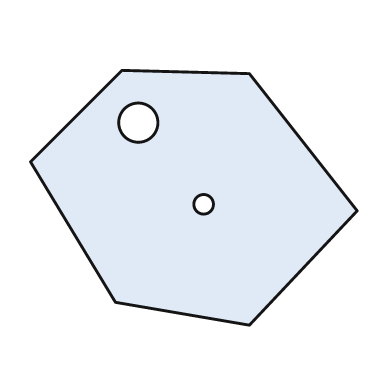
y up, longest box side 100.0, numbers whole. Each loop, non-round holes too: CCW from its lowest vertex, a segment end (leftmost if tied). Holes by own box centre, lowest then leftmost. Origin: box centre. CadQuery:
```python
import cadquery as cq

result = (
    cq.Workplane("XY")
    .moveTo(17.0, -39.0)
    .lineTo(50.0, -4.0)
    .lineTo(17.0, 38.0)
    .lineTo(-22.0, 39.0)
    .lineTo(-50.0, 11.0)
    .lineTo(-24.0, -32.0)
    .close()
    .moveTo(3.0, -2.0)
    .circle(3.0)
    .moveTo(-17.0, 23.0)
    .circle(6.0)
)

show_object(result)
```